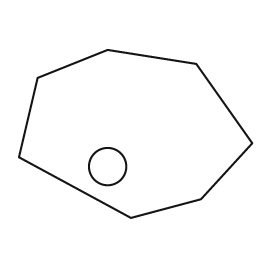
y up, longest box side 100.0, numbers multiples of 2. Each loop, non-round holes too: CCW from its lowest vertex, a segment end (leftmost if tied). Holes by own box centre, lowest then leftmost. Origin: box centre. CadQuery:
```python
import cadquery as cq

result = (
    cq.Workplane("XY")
    .moveTo(-2.0, -36.0)
    .lineTo(28.0, -28.0)
    .lineTo(50.0, -4.0)
    .lineTo(26.0, 30.0)
    .lineTo(-12.0, 36.0)
    .lineTo(-42.0, 24.0)
    .lineTo(-50.0, -10.0)
    .close()
    .moveTo(-12.0, -14.0)
    .circle(8.0)
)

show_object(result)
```